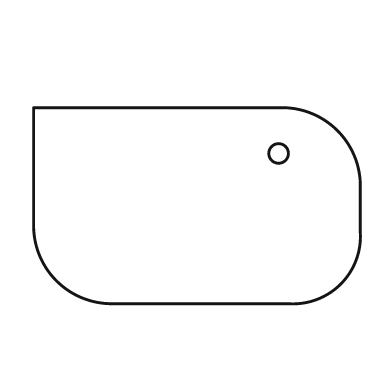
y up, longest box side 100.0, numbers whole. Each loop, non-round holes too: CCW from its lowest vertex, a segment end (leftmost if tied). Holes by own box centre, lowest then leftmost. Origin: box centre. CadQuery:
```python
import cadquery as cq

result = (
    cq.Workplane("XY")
    .moveTo(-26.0, -30.0)
    .lineTo(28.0, -30.0)
    .threePointArc((44.0, -24.0), (50.0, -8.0))
    .lineTo(50.0, 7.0)
    .threePointArc((43.0, 23.0), (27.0, 30.0))
    .lineTo(-50.0, 30.0)
    .lineTo(-50.0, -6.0)
    .threePointArc((-43.0, -23.0), (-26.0, -30.0))
    .close()
    .moveTo(25.0, 16.0)
    .circle(3.0)
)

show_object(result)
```